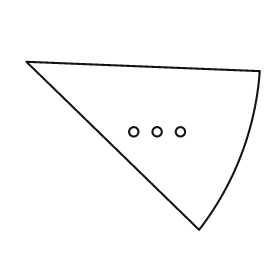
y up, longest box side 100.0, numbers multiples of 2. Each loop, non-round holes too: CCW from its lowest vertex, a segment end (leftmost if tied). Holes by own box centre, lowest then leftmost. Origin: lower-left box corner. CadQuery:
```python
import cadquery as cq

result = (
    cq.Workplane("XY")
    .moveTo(74.0, 0.0)
    .threePointArc((92.0, 32.0), (100.0, 68.0))
    .lineTo(0.0, 72.0)
    .close()
    .moveTo(46.0, 42.0)
    .circle(2.0)
    .moveTo(56.0, 42.0)
    .circle(2.0)
    .moveTo(66.0, 42.0)
    .circle(2.0)
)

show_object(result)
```